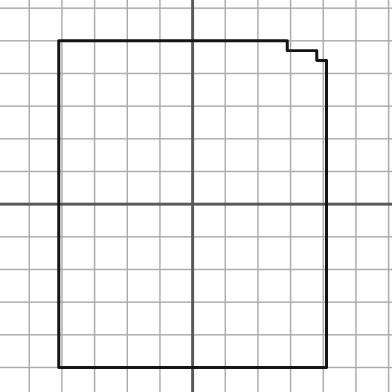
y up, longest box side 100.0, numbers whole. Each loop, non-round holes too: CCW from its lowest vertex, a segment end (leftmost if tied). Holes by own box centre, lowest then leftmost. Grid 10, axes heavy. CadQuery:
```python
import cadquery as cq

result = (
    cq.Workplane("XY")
    .moveTo(-41.0, -50.0)
    .lineTo(41.0, -50.0)
    .lineTo(41.0, 44.0)
    .lineTo(38.0, 44.0)
    .lineTo(38.0, 47.0)
    .lineTo(29.0, 47.0)
    .lineTo(29.0, 50.0)
    .lineTo(-41.0, 50.0)
    .close()
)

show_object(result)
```